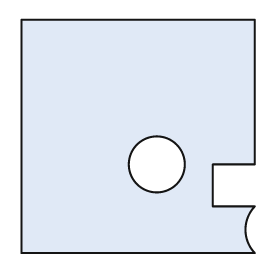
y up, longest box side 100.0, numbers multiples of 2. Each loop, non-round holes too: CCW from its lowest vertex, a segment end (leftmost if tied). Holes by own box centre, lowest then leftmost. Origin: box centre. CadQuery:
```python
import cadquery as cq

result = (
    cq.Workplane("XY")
    .moveTo(-50.0, -50.0)
    .lineTo(50.0, -50.0)
    .threePointArc((46.0, -40.0), (50.0, -30.0))
    .lineTo(32.0, -30.0)
    .lineTo(32.0, -12.0)
    .lineTo(50.0, -12.0)
    .lineTo(50.0, 50.0)
    .lineTo(-50.0, 50.0)
    .close()
    .moveTo(8.0, -12.0)
    .circle(12.0)
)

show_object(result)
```